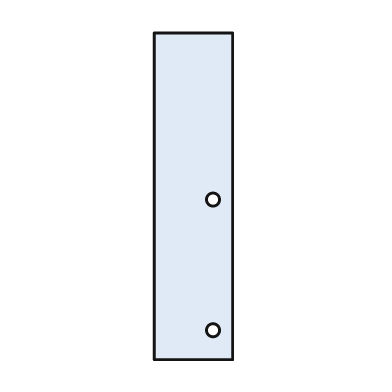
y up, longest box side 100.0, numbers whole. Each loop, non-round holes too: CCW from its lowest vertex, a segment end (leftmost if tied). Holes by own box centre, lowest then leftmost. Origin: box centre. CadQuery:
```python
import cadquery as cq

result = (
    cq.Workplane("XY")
    .moveTo(-12.0, -50.0)
    .lineTo(12.0, -50.0)
    .lineTo(12.0, 50.0)
    .lineTo(-12.0, 50.0)
    .close()
    .moveTo(6.0, -41.0)
    .circle(2.0)
    .moveTo(6.0, -1.0)
    .circle(2.0)
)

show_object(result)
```